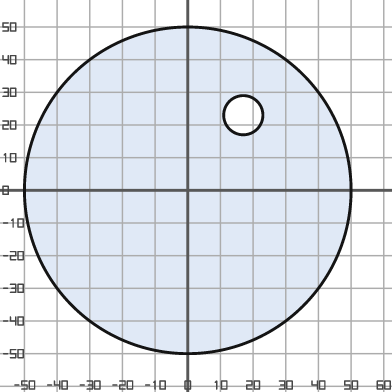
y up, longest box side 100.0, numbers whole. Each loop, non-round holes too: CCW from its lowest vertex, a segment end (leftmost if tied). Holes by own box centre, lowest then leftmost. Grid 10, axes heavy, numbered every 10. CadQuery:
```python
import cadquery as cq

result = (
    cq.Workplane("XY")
    .moveTo(0.0, 0.0)
    .circle(50.0)
    .moveTo(17.0, 23.0)
    .circle(6.0)
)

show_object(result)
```